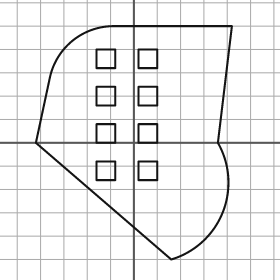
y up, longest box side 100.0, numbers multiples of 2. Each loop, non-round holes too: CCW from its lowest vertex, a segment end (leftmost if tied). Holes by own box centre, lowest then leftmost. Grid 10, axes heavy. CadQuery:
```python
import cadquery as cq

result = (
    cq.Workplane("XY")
    .moveTo(16.0, -50.0)
    .threePointArc((38.0, -30.0), (36.0, 0.0))
    .lineTo(42.0, 50.0)
    .lineTo(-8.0, 50.0)
    .threePointArc((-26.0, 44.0), (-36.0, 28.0))
    .lineTo(-42.0, 0.0)
    .close()
    .moveTo(-16.0, -16.0)
    .lineTo(-8.0, -16.0)
    .lineTo(-8.0, -8.0)
    .lineTo(-16.0, -8.0)
    .close()
    .moveTo(2.0, -16.0)
    .lineTo(10.0, -16.0)
    .lineTo(10.0, -8.0)
    .lineTo(2.0, -8.0)
    .close()
    .moveTo(-16.0, 0.0)
    .lineTo(-8.0, 0.0)
    .lineTo(-8.0, 8.0)
    .lineTo(-16.0, 8.0)
    .close()
    .moveTo(2.0, 0.0)
    .lineTo(10.0, 0.0)
    .lineTo(10.0, 8.0)
    .lineTo(2.0, 8.0)
    .close()
    .moveTo(-16.0, 16.0)
    .lineTo(-8.0, 16.0)
    .lineTo(-8.0, 24.0)
    .lineTo(-16.0, 24.0)
    .close()
    .moveTo(2.0, 16.0)
    .lineTo(10.0, 16.0)
    .lineTo(10.0, 24.0)
    .lineTo(2.0, 24.0)
    .close()
    .moveTo(-16.0, 32.0)
    .lineTo(-8.0, 32.0)
    .lineTo(-8.0, 40.0)
    .lineTo(-16.0, 40.0)
    .close()
    .moveTo(2.0, 32.0)
    .lineTo(10.0, 32.0)
    .lineTo(10.0, 40.0)
    .lineTo(2.0, 40.0)
    .close()
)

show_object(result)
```